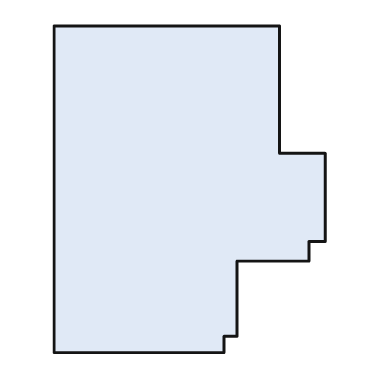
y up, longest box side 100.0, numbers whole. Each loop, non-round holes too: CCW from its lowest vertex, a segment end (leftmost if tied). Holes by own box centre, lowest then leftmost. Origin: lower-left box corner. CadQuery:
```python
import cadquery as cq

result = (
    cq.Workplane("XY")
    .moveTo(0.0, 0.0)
    .lineTo(52.0, 0.0)
    .lineTo(52.0, 5.0)
    .lineTo(56.0, 5.0)
    .lineTo(56.0, 28.0)
    .lineTo(78.0, 28.0)
    .lineTo(78.0, 34.0)
    .lineTo(83.0, 34.0)
    .lineTo(83.0, 61.0)
    .lineTo(69.0, 61.0)
    .lineTo(69.0, 100.0)
    .lineTo(0.0, 100.0)
    .close()
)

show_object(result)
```